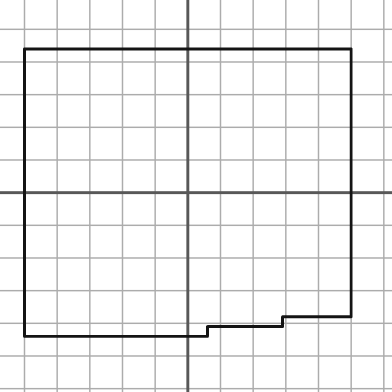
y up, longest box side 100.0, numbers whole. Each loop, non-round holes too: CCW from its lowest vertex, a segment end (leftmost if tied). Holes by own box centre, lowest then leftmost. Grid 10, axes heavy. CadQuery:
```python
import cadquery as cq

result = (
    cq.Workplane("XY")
    .moveTo(-50.0, -44.0)
    .lineTo(6.0, -44.0)
    .lineTo(6.0, -41.0)
    .lineTo(29.0, -41.0)
    .lineTo(29.0, -38.0)
    .lineTo(50.0, -38.0)
    .lineTo(50.0, 44.0)
    .lineTo(-50.0, 44.0)
    .close()
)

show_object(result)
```